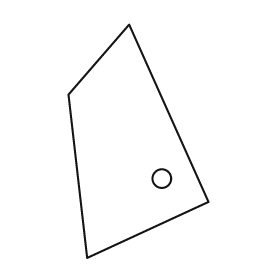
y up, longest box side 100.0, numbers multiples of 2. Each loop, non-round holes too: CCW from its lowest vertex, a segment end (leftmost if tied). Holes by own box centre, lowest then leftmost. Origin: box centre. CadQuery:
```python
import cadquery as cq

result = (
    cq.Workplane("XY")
    .moveTo(-22.0, -50.0)
    .lineTo(30.0, -26.0)
    .lineTo(-4.0, 50.0)
    .lineTo(-30.0, 20.0)
    .close()
    .moveTo(10.0, -16.0)
    .circle(4.0)
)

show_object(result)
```